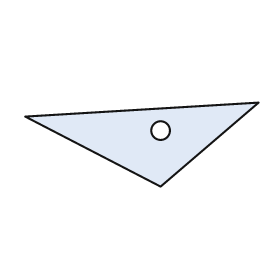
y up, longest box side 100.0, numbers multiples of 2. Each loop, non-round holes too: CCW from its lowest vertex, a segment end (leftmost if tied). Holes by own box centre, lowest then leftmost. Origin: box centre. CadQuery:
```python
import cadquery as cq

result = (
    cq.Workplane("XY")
    .moveTo(8.0, -18.0)
    .lineTo(50.0, 18.0)
    .lineTo(-50.0, 12.0)
    .close()
    .moveTo(8.0, 6.0)
    .circle(4.0)
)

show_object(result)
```